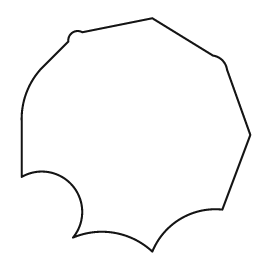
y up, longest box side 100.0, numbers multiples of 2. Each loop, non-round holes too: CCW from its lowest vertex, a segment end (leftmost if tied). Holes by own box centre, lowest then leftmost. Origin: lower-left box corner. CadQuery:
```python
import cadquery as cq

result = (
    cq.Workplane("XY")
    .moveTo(56.0, 0.0)
    .threePointArc((68.0, 14.0), (86.0, 18.0))
    .lineTo(98.0, 50.0)
    .lineTo(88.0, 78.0)
    .threePointArc((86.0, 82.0), (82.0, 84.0))
    .lineTo(56.0, 100.0)
    .lineTo(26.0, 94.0)
    .threePointArc((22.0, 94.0), (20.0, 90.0))
    .lineTo(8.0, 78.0)
    .threePointArc((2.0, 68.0), (0.0, 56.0))
    .lineTo(0.0, 32.0)
    .threePointArc((22.0, 28.0), (22.0, 6.0))
    .threePointArc((40.0, 8.0), (56.0, 0.0))
    .close()
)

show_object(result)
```